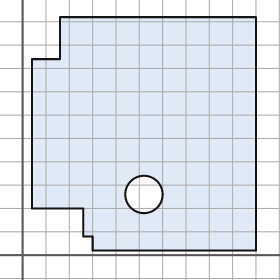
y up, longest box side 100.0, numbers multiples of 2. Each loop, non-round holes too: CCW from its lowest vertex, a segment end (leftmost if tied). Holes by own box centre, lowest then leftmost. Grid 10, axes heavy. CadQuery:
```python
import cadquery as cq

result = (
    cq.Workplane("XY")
    .moveTo(30.0, 2.0)
    .lineTo(100.0, 2.0)
    .lineTo(100.0, 102.0)
    .lineTo(16.0, 102.0)
    .lineTo(16.0, 84.0)
    .lineTo(4.0, 84.0)
    .lineTo(4.0, 20.0)
    .lineTo(26.0, 20.0)
    .lineTo(26.0, 8.0)
    .lineTo(30.0, 8.0)
    .close()
    .moveTo(52.0, 26.0)
    .circle(8.0)
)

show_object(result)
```